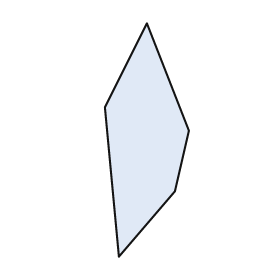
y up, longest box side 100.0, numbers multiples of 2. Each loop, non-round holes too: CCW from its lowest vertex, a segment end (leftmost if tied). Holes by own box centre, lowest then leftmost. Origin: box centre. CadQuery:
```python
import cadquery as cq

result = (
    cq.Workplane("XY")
    .moveTo(-12.0, -50.0)
    .lineTo(12.0, -22.0)
    .lineTo(18.0, 4.0)
    .lineTo(0.0, 50.0)
    .lineTo(-18.0, 14.0)
    .close()
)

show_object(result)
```